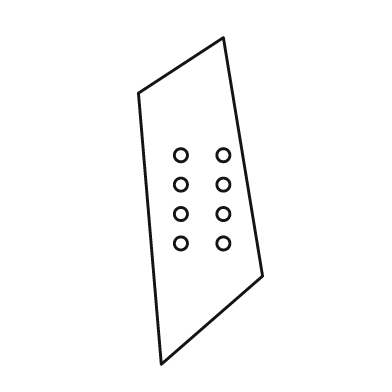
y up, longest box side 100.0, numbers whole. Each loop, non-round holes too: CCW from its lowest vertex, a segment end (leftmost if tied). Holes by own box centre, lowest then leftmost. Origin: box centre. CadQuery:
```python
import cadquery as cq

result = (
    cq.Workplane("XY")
    .moveTo(-12.0, -50.0)
    .lineTo(19.0, -23.0)
    .lineTo(7.0, 50.0)
    .lineTo(-19.0, 33.0)
    .close()
    .moveTo(-6.0, -13.0)
    .circle(2.0)
    .moveTo(7.0, -13.0)
    .circle(2.0)
    .moveTo(-6.0, -4.0)
    .circle(2.0)
    .moveTo(7.0, -4.0)
    .circle(2.0)
    .moveTo(-6.0, 5.0)
    .circle(2.0)
    .moveTo(7.0, 5.0)
    .circle(2.0)
    .moveTo(-6.0, 14.0)
    .circle(2.0)
    .moveTo(7.0, 14.0)
    .circle(2.0)
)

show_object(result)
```